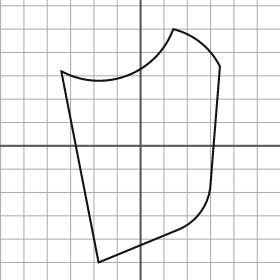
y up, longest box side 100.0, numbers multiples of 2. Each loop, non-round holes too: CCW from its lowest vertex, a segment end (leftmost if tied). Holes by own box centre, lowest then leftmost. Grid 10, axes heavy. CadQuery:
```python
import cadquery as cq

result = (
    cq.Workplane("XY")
    .moveTo(-18.0, -50.0)
    .lineTo(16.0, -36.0)
    .threePointArc((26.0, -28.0), (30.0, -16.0))
    .lineTo(34.0, 34.0)
    .threePointArc((26.0, 44.0), (14.0, 50.0))
    .threePointArc((-6.0, 30.0), (-34.0, 32.0))
    .close()
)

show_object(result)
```